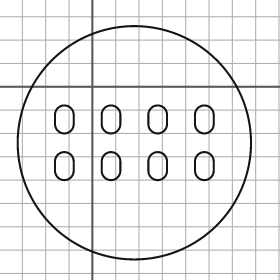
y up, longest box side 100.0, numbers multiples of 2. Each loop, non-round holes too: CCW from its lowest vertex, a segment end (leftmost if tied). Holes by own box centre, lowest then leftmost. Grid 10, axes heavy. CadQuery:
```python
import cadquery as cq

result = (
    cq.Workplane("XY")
    .moveTo(18.0, -24.0)
    .circle(50.0)
    .moveTo(-16.0, -36.0)
    .threePointArc((-12.0, -40.0), (-8.0, -36.0))
    .lineTo(-8.0, -32.0)
    .threePointArc((-12.0, -28.0), (-16.0, -32.0))
    .close()
    .moveTo(4.0, -36.0)
    .threePointArc((8.0, -40.0), (12.0, -36.0))
    .lineTo(12.0, -32.0)
    .threePointArc((8.0, -28.0), (4.0, -32.0))
    .close()
    .moveTo(24.0, -36.0)
    .threePointArc((28.0, -40.0), (32.0, -36.0))
    .lineTo(32.0, -32.0)
    .threePointArc((28.0, -28.0), (24.0, -32.0))
    .close()
    .moveTo(44.0, -36.0)
    .threePointArc((48.0, -40.0), (52.0, -36.0))
    .lineTo(52.0, -32.0)
    .threePointArc((48.0, -28.0), (44.0, -32.0))
    .close()
    .moveTo(-16.0, -16.0)
    .threePointArc((-12.0, -20.0), (-8.0, -16.0))
    .lineTo(-8.0, -12.0)
    .threePointArc((-12.0, -8.0), (-16.0, -12.0))
    .close()
    .moveTo(4.0, -16.0)
    .threePointArc((8.0, -20.0), (12.0, -16.0))
    .lineTo(12.0, -12.0)
    .threePointArc((8.0, -8.0), (4.0, -12.0))
    .close()
    .moveTo(24.0, -16.0)
    .threePointArc((28.0, -20.0), (32.0, -16.0))
    .lineTo(32.0, -12.0)
    .threePointArc((28.0, -8.0), (24.0, -12.0))
    .close()
    .moveTo(44.0, -16.0)
    .threePointArc((48.0, -20.0), (52.0, -16.0))
    .lineTo(52.0, -12.0)
    .threePointArc((48.0, -8.0), (44.0, -12.0))
    .close()
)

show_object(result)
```